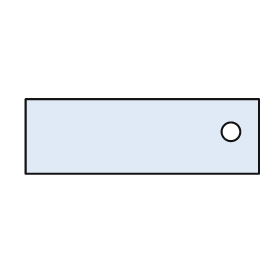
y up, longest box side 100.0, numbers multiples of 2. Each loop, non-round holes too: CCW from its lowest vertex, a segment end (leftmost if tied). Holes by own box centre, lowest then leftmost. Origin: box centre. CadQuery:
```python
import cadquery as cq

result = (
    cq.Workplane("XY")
    .moveTo(-50.0, -16.0)
    .lineTo(50.0, -16.0)
    .lineTo(50.0, 16.0)
    .lineTo(-50.0, 16.0)
    .close()
    .moveTo(38.0, 2.0)
    .circle(4.0)
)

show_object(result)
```